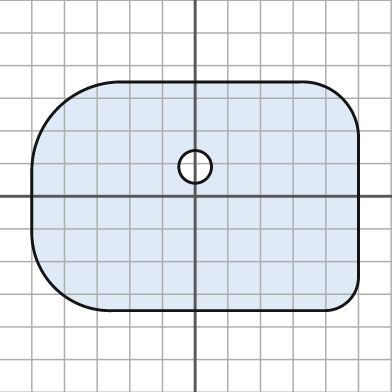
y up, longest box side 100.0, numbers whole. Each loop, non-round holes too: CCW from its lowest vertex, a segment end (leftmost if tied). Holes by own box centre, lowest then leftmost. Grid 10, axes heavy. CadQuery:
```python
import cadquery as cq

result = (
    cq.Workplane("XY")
    .moveTo(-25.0, -35.0)
    .lineTo(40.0, -35.0)
    .threePointArc((47.0, -32.0), (50.0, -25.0))
    .lineTo(50.0, 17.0)
    .threePointArc((45.0, 30.0), (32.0, 35.0))
    .lineTo(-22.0, 35.0)
    .threePointArc((-42.0, 27.0), (-50.0, 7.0))
    .lineTo(-50.0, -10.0)
    .threePointArc((-43.0, -28.0), (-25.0, -35.0))
    .close()
    .moveTo(0.0, 9.0)
    .circle(5.0)
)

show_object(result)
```